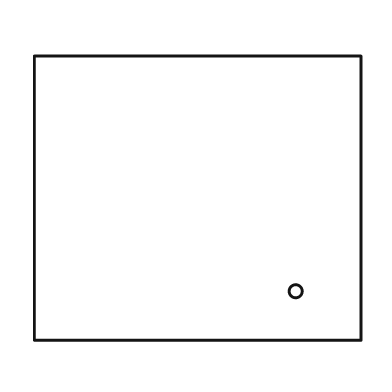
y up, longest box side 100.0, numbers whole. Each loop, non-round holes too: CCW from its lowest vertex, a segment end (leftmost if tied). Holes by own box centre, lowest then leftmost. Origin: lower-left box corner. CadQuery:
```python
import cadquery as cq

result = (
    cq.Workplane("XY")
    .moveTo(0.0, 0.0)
    .lineTo(100.0, 0.0)
    .lineTo(100.0, 87.0)
    .lineTo(0.0, 87.0)
    .close()
    .moveTo(80.0, 15.0)
    .circle(2.0)
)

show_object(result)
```